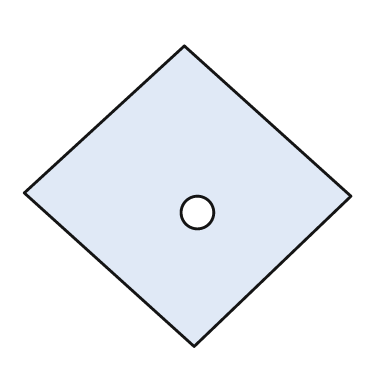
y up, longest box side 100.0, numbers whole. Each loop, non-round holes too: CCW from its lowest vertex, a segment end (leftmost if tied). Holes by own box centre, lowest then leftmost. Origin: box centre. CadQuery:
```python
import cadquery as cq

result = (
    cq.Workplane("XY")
    .moveTo(2.0, -46.0)
    .lineTo(50.0, 0.0)
    .lineTo(-1.0, 46.0)
    .lineTo(-50.0, 1.0)
    .close()
    .moveTo(3.0, -5.0)
    .circle(5.0)
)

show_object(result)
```